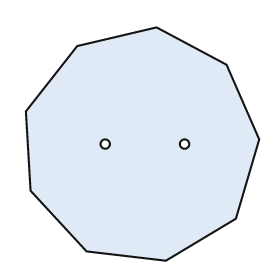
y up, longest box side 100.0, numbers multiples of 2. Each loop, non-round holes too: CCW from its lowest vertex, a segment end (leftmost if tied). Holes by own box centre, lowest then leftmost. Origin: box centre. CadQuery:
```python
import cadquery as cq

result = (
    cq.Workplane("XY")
    .moveTo(10.0, -50.0)
    .lineTo(40.0, -32.0)
    .lineTo(50.0, 2.0)
    .lineTo(36.0, 34.0)
    .lineTo(6.0, 50.0)
    .lineTo(-28.0, 42.0)
    .lineTo(-50.0, 14.0)
    .lineTo(-48.0, -20.0)
    .lineTo(-24.0, -46.0)
    .close()
    .moveTo(-16.0, 0.0)
    .circle(2.0)
    .moveTo(18.0, 0.0)
    .circle(2.0)
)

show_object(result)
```